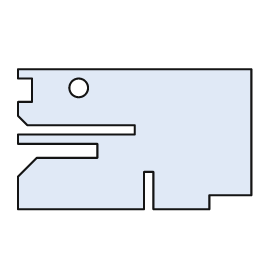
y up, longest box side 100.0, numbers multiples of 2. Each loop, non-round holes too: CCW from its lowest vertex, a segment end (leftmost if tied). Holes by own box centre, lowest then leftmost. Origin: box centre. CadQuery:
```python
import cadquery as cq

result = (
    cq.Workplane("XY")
    .moveTo(-50.0, -30.0)
    .lineTo(4.0, -30.0)
    .lineTo(4.0, -14.0)
    .lineTo(8.0, -14.0)
    .lineTo(8.0, -30.0)
    .lineTo(32.0, -30.0)
    .lineTo(32.0, -24.0)
    .lineTo(50.0, -24.0)
    .lineTo(50.0, 30.0)
    .lineTo(-50.0, 30.0)
    .lineTo(-50.0, 26.0)
    .lineTo(-44.0, 26.0)
    .lineTo(-44.0, 16.0)
    .lineTo(-50.0, 16.0)
    .lineTo(-50.0, 10.0)
    .lineTo(-46.0, 6.0)
    .lineTo(0.0, 6.0)
    .lineTo(0.0, 2.0)
    .lineTo(-50.0, 2.0)
    .lineTo(-50.0, -2.0)
    .lineTo(-16.0, -2.0)
    .lineTo(-16.0, -8.0)
    .lineTo(-42.0, -8.0)
    .lineTo(-50.0, -16.0)
    .close()
    .moveTo(-24.0, 22.0)
    .circle(4.0)
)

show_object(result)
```